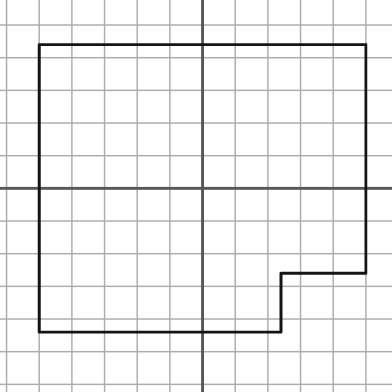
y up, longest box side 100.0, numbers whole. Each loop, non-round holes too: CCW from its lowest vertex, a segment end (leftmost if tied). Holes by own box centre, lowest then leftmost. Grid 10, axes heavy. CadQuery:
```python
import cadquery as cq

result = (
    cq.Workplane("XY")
    .moveTo(-50.0, -44.0)
    .lineTo(24.0, -44.0)
    .lineTo(24.0, -26.0)
    .lineTo(50.0, -26.0)
    .lineTo(50.0, 44.0)
    .lineTo(-50.0, 44.0)
    .close()
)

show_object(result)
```